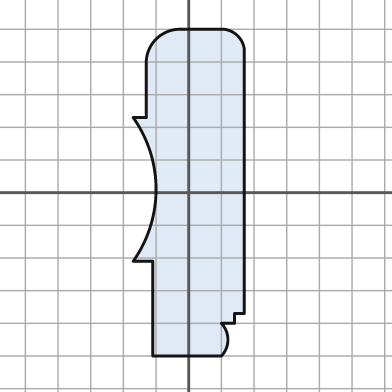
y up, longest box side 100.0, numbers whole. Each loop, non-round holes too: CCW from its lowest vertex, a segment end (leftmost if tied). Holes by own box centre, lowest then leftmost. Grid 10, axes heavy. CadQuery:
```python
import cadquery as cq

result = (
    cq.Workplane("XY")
    .moveTo(-11.0, -50.0)
    .lineTo(10.0, -50.0)
    .threePointArc((12.0, -45.0), (10.0, -40.0))
    .lineTo(14.0, -40.0)
    .lineTo(14.0, -37.0)
    .lineTo(17.0, -37.0)
    .lineTo(17.0, 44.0)
    .threePointArc((15.0, 48.0), (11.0, 50.0))
    .lineTo(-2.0, 50.0)
    .threePointArc((-10.0, 47.0), (-13.0, 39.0))
    .lineTo(-13.0, 23.0)
    .lineTo(-17.0, 23.0)
    .threePointArc((-10.0, 1.0), (-17.0, -21.0))
    .lineTo(-11.0, -21.0)
    .close()
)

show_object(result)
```